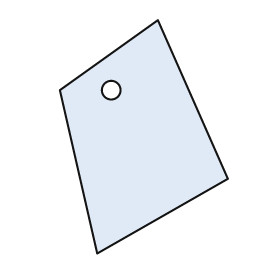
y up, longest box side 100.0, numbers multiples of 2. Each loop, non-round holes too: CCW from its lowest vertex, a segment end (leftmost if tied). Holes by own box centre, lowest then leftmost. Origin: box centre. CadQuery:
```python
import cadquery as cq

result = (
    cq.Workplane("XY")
    .moveTo(-20.0, -50.0)
    .lineTo(36.0, -18.0)
    .lineTo(6.0, 50.0)
    .lineTo(-36.0, 20.0)
    .close()
    .moveTo(-14.0, 20.0)
    .circle(4.0)
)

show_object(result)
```